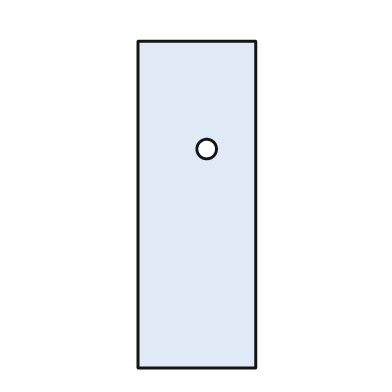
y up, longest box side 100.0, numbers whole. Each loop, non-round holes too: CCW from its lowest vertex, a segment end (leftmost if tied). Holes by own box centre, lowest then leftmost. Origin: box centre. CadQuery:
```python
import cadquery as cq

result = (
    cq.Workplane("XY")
    .moveTo(-18.0, -50.0)
    .lineTo(18.0, -50.0)
    .lineTo(18.0, 50.0)
    .lineTo(-18.0, 50.0)
    .close()
    .moveTo(3.0, 17.0)
    .circle(3.0)
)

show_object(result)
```